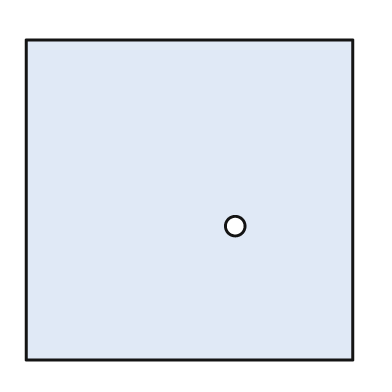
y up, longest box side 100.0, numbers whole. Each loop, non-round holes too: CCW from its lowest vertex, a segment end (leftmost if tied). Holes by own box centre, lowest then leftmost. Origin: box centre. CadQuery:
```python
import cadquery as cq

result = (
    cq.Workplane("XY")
    .moveTo(-50.0, -49.0)
    .lineTo(50.0, -49.0)
    .lineTo(50.0, 49.0)
    .lineTo(-50.0, 49.0)
    .close()
    .moveTo(14.0, -8.0)
    .circle(3.0)
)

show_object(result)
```